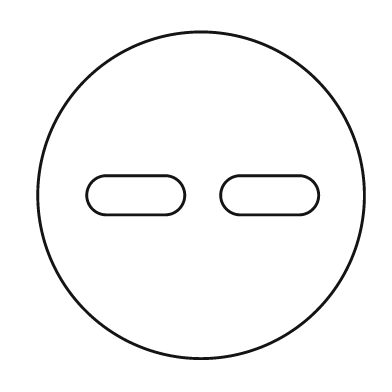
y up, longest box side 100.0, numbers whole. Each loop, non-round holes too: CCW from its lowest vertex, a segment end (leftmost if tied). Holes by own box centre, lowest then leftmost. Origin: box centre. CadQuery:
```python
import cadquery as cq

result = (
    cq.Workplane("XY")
    .moveTo(0.0, 0.0)
    .circle(50.0)
    .moveTo(-29.0, -6.0)
    .lineTo(-11.0, -6.0)
    .threePointArc((-5.0, 0.0), (-11.0, 6.0))
    .lineTo(-29.0, 6.0)
    .threePointArc((-35.0, 0.0), (-29.0, -6.0))
    .close()
    .moveTo(12.0, -6.0)
    .lineTo(30.0, -6.0)
    .threePointArc((36.0, 0.0), (30.0, 6.0))
    .lineTo(12.0, 6.0)
    .threePointArc((6.0, 0.0), (12.0, -6.0))
    .close()
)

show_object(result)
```